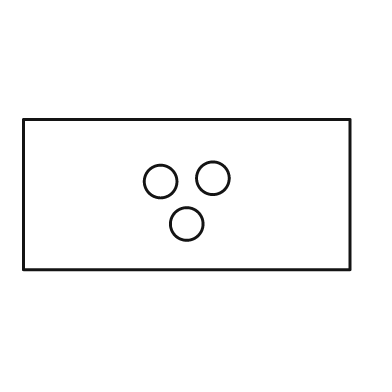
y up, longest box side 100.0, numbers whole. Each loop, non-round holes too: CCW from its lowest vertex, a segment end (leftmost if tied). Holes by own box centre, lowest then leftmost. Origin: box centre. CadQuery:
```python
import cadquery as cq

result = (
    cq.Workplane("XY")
    .moveTo(-50.0, -23.0)
    .lineTo(50.0, -23.0)
    .lineTo(50.0, 23.0)
    .lineTo(-50.0, 23.0)
    .close()
    .moveTo(0.0, -9.0)
    .circle(5.0)
    .moveTo(-8.0, 4.0)
    .circle(5.0)
    .moveTo(8.0, 5.0)
    .circle(5.0)
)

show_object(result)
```